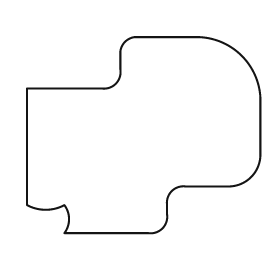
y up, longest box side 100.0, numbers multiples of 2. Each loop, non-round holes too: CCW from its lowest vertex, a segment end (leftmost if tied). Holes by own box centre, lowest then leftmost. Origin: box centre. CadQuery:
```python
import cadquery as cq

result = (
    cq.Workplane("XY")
    .moveTo(-34.0, -42.0)
    .lineTo(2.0, -42.0)
    .threePointArc((8.0, -40.0), (10.0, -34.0))
    .lineTo(10.0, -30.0)
    .threePointArc((12.0, -24.0), (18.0, -22.0))
    .lineTo(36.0, -22.0)
    .threePointArc((46.0, -18.0), (50.0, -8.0))
    .lineTo(50.0, 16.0)
    .threePointArc((42.0, 34.0), (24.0, 42.0))
    .lineTo(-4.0, 42.0)
    .threePointArc((-8.0, 40.0), (-10.0, 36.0))
    .lineTo(-10.0, 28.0)
    .threePointArc((-12.0, 22.0), (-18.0, 20.0))
    .lineTo(-50.0, 20.0)
    .lineTo(-50.0, -30.0)
    .threePointArc((-42.0, -32.0), (-34.0, -30.0))
    .threePointArc((-32.0, -36.0), (-34.0, -42.0))
    .close()
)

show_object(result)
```